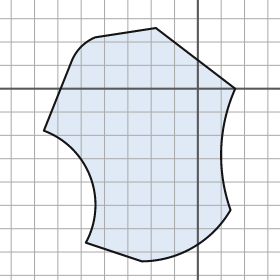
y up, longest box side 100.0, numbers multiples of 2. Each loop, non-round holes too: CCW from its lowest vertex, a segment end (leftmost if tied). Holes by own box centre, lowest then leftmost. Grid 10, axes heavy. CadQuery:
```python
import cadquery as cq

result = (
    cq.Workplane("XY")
    .moveTo(-24.0, -74.0)
    .threePointArc((-2.0, -68.0), (14.0, -52.0))
    .threePointArc((10.0, -26.0), (16.0, 0.0))
    .lineTo(-18.0, 26.0)
    .lineTo(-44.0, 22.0)
    .threePointArc((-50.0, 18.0), (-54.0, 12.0))
    .lineTo(-66.0, -18.0)
    .threePointArc((-46.0, -38.0), (-48.0, -66.0))
    .close()
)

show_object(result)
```